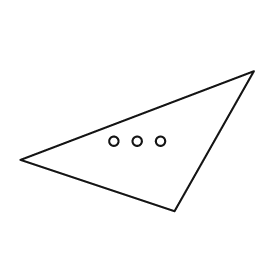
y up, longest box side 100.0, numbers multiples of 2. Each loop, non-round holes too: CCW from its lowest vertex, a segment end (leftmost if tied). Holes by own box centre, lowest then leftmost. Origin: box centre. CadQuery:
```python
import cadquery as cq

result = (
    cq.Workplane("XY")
    .moveTo(16.0, -30.0)
    .lineTo(50.0, 30.0)
    .lineTo(-50.0, -8.0)
    .close()
    .moveTo(-10.0, 0.0)
    .circle(2.0)
    .moveTo(0.0, 0.0)
    .circle(2.0)
    .moveTo(10.0, 0.0)
    .circle(2.0)
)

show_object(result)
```